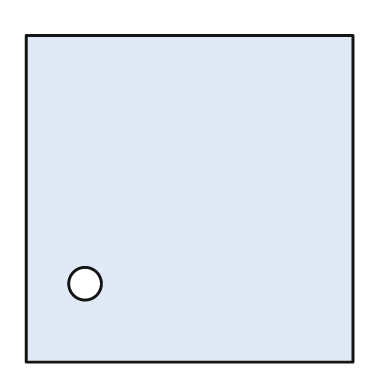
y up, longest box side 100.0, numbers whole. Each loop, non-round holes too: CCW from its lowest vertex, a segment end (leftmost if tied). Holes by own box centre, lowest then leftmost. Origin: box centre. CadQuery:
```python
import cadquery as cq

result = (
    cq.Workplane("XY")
    .moveTo(-50.0, -50.0)
    .lineTo(50.0, -50.0)
    .lineTo(50.0, 50.0)
    .lineTo(-50.0, 50.0)
    .close()
    .moveTo(-32.0, -26.0)
    .circle(5.0)
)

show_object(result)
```